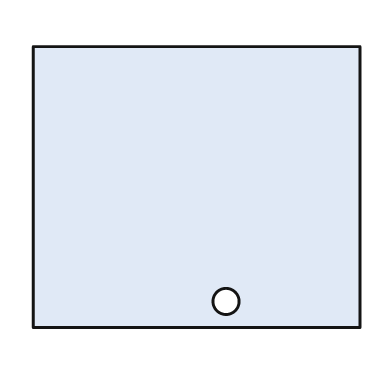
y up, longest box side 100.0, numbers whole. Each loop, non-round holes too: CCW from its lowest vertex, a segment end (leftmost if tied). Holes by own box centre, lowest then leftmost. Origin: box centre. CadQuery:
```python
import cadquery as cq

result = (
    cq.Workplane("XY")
    .moveTo(-50.0, -43.0)
    .lineTo(50.0, -43.0)
    .lineTo(50.0, 43.0)
    .lineTo(-50.0, 43.0)
    .close()
    .moveTo(9.0, -35.0)
    .circle(4.0)
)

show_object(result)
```